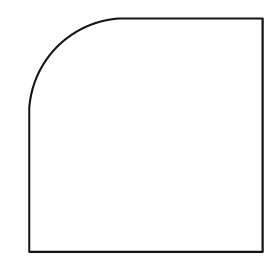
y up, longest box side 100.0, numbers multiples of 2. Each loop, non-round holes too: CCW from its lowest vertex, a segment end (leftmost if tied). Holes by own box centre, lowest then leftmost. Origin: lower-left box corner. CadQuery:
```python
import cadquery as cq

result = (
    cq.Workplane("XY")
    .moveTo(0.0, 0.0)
    .lineTo(100.0, 0.0)
    .lineTo(100.0, 100.0)
    .lineTo(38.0, 100.0)
    .threePointArc((12.0, 88.0), (0.0, 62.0))
    .close()
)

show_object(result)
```